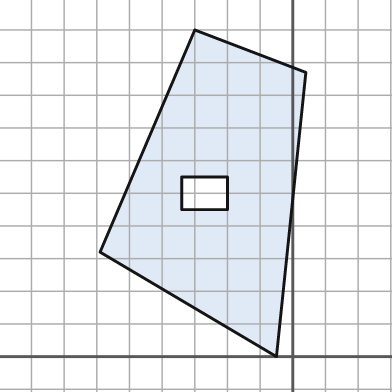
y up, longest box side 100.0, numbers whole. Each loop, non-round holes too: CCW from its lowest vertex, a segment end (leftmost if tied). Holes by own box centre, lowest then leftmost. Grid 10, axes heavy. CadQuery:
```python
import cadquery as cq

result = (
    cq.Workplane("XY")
    .moveTo(-5.0, 0.0)
    .lineTo(4.0, 87.0)
    .lineTo(-30.0, 100.0)
    .lineTo(-59.0, 32.0)
    .close()
    .moveTo(-34.0, 45.0)
    .lineTo(-20.0, 45.0)
    .lineTo(-20.0, 55.0)
    .lineTo(-34.0, 55.0)
    .close()
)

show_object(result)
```